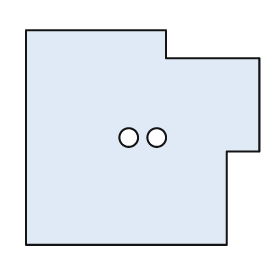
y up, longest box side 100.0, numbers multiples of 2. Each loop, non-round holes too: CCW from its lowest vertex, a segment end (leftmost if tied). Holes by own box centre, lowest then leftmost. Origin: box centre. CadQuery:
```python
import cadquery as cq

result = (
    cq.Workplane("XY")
    .moveTo(-50.0, -46.0)
    .lineTo(36.0, -46.0)
    .lineTo(36.0, -6.0)
    .lineTo(50.0, -6.0)
    .lineTo(50.0, 34.0)
    .lineTo(10.0, 34.0)
    .lineTo(10.0, 46.0)
    .lineTo(-50.0, 46.0)
    .close()
    .moveTo(-6.0, 0.0)
    .circle(4.0)
    .moveTo(6.0, 0.0)
    .circle(4.0)
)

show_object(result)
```